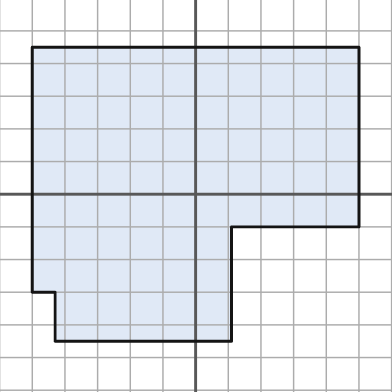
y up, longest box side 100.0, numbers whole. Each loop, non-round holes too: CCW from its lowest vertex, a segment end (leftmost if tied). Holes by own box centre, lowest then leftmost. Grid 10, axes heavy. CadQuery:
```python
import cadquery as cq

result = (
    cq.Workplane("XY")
    .moveTo(-43.0, -45.0)
    .lineTo(11.0, -45.0)
    .lineTo(11.0, -10.0)
    .lineTo(50.0, -10.0)
    .lineTo(50.0, 45.0)
    .lineTo(-50.0, 45.0)
    .lineTo(-50.0, -30.0)
    .lineTo(-43.0, -30.0)
    .close()
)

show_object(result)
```